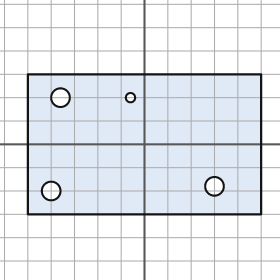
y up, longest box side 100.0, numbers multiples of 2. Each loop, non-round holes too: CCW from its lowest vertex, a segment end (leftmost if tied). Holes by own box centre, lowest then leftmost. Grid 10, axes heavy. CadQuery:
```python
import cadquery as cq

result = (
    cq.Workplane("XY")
    .moveTo(-50.0, -30.0)
    .lineTo(50.0, -30.0)
    .lineTo(50.0, 30.0)
    .lineTo(-50.0, 30.0)
    .close()
    .moveTo(-40.0, -20.0)
    .circle(4.0)
    .moveTo(30.0, -18.0)
    .circle(4.0)
    .moveTo(-36.0, 20.0)
    .circle(4.0)
    .moveTo(-6.0, 20.0)
    .circle(2.0)
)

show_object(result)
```